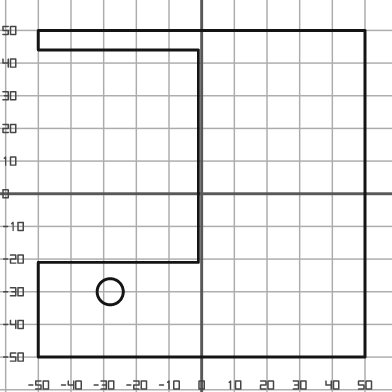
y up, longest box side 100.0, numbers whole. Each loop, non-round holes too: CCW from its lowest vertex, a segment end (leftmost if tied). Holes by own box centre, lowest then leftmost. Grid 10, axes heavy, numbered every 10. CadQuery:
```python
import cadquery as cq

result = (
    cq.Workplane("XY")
    .moveTo(-50.0, -50.0)
    .lineTo(50.0, -50.0)
    .lineTo(50.0, 50.0)
    .lineTo(-50.0, 50.0)
    .lineTo(-50.0, 44.0)
    .lineTo(-1.0, 44.0)
    .lineTo(-1.0, -21.0)
    .lineTo(-50.0, -21.0)
    .close()
    .moveTo(-28.0, -30.0)
    .circle(4.0)
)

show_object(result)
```